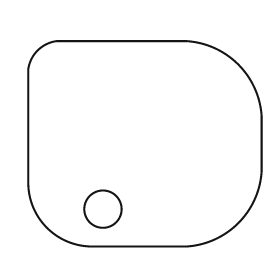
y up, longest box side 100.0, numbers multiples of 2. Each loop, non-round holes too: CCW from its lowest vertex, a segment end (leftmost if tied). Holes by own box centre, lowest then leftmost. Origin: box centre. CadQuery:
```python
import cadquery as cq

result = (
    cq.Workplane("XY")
    .moveTo(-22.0, -44.0)
    .lineTo(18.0, -44.0)
    .threePointArc((40.0, -34.0), (50.0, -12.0))
    .lineTo(50.0, 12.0)
    .threePointArc((40.0, 34.0), (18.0, 44.0))
    .lineTo(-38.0, 44.0)
    .threePointArc((-46.0, 40.0), (-50.0, 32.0))
    .lineTo(-50.0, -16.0)
    .threePointArc((-42.0, -36.0), (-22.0, -44.0))
    .close()
    .moveTo(-18.0, -28.0)
    .circle(8.0)
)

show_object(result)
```